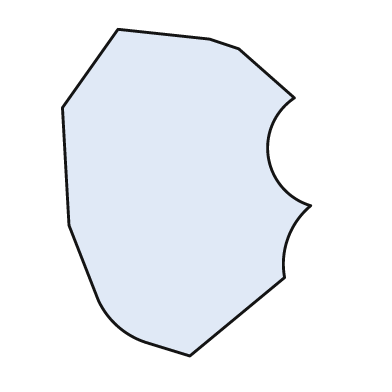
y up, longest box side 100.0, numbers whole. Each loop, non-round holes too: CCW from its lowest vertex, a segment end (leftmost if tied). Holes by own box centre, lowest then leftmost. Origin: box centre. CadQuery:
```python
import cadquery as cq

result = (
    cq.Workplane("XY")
    .moveTo(1.0, -50.0)
    .lineTo(30.0, -26.0)
    .threePointArc((31.0, -14.0), (38.0, -4.0))
    .threePointArc((25.0, 11.0), (33.0, 29.0))
    .lineTo(16.0, 44.0)
    .lineTo(7.0, 47.0)
    .lineTo(-21.0, 50.0)
    .lineTo(-38.0, 26.0)
    .lineTo(-36.0, -10.0)
    .lineTo(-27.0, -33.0)
    .threePointArc((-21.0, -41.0), (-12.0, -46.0))
    .close()
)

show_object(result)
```